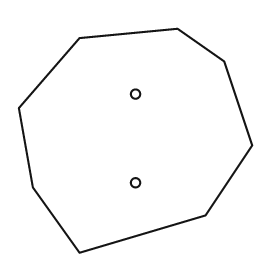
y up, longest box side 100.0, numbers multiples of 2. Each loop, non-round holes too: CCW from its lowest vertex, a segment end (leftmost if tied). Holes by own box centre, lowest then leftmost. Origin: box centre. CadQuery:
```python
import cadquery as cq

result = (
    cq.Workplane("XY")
    .moveTo(-24.0, -48.0)
    .lineTo(30.0, -32.0)
    .lineTo(50.0, -2.0)
    .lineTo(38.0, 34.0)
    .lineTo(18.0, 48.0)
    .lineTo(-24.0, 44.0)
    .lineTo(-50.0, 14.0)
    .lineTo(-44.0, -20.0)
    .close()
    .moveTo(0.0, -18.0)
    .circle(2.0)
    .moveTo(0.0, 20.0)
    .circle(2.0)
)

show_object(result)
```